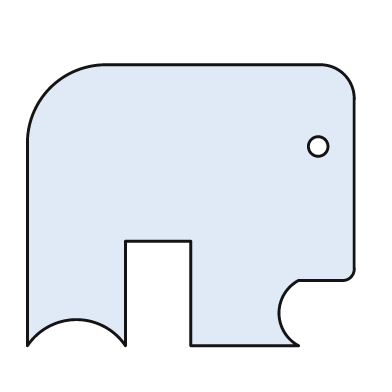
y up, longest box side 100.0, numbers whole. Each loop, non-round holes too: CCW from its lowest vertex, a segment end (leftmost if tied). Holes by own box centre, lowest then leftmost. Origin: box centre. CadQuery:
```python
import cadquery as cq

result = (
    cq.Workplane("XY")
    .moveTo(-50.0, -43.0)
    .threePointArc((-35.0, -35.0), (-20.0, -43.0))
    .lineTo(-20.0, -11.0)
    .lineTo(0.0, -11.0)
    .lineTo(0.0, -43.0)
    .lineTo(33.0, -43.0)
    .threePointArc((27.0, -33.0), (33.0, -23.0))
    .lineTo(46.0, -23.0)
    .threePointArc((49.0, -22.0), (50.0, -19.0))
    .lineTo(50.0, 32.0)
    .threePointArc((47.0, 40.0), (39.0, 43.0))
    .lineTo(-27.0, 43.0)
    .threePointArc((-43.0, 36.0), (-50.0, 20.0))
    .close()
    .moveTo(39.0, 18.0)
    .circle(3.0)
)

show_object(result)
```